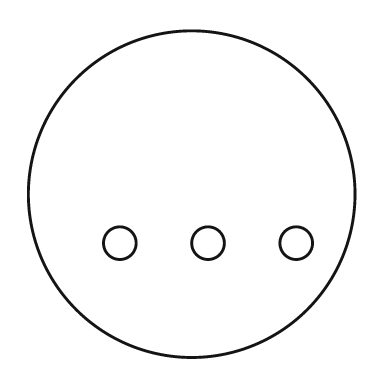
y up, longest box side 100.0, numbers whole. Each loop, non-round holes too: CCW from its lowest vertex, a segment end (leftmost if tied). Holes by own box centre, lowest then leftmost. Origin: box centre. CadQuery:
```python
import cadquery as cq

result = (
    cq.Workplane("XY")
    .moveTo(0.0, 0.0)
    .circle(50.0)
    .moveTo(-22.0, -15.0)
    .circle(5.0)
    .moveTo(5.0, -15.0)
    .circle(5.0)
    .moveTo(32.0, -15.0)
    .circle(5.0)
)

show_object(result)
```